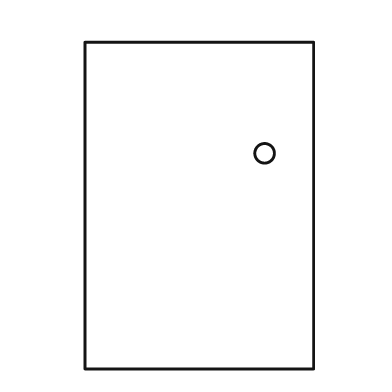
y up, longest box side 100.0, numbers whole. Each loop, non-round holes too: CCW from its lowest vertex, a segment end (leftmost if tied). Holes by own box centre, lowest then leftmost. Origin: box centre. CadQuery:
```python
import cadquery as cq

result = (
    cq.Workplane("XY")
    .moveTo(-35.0, -50.0)
    .lineTo(35.0, -50.0)
    .lineTo(35.0, 50.0)
    .lineTo(-35.0, 50.0)
    .close()
    .moveTo(20.0, 16.0)
    .circle(3.0)
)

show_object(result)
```